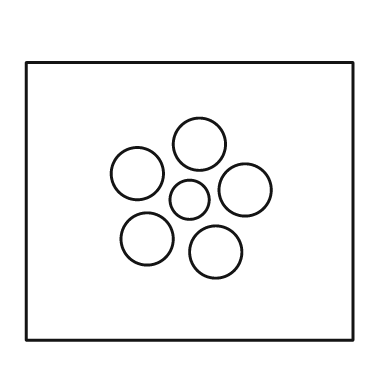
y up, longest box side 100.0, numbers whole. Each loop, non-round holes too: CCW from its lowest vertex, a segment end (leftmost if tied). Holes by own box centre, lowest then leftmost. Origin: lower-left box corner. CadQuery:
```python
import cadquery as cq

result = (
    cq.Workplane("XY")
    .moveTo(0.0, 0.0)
    .lineTo(100.0, 0.0)
    .lineTo(100.0, 85.0)
    .lineTo(0.0, 85.0)
    .close()
    .moveTo(58.0, 27.0)
    .circle(8.0)
    .moveTo(37.0, 31.0)
    .circle(8.0)
    .moveTo(50.0, 43.0)
    .circle(6.0)
    .moveTo(67.0, 46.0)
    .circle(8.0)
    .moveTo(34.0, 51.0)
    .circle(8.0)
    .moveTo(53.0, 60.0)
    .circle(8.0)
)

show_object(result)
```